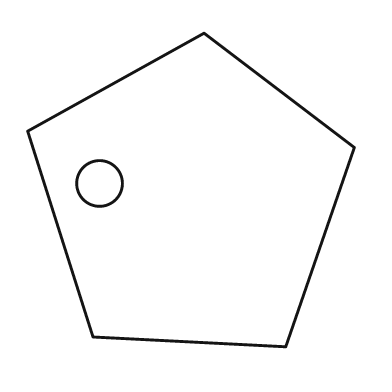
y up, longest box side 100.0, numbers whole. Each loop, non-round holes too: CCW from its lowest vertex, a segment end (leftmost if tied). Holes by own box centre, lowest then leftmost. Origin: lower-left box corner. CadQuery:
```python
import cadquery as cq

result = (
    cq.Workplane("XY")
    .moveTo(79.0, 0.0)
    .lineTo(100.0, 61.0)
    .lineTo(54.0, 96.0)
    .lineTo(0.0, 66.0)
    .lineTo(20.0, 3.0)
    .close()
    .moveTo(22.0, 50.0)
    .circle(7.0)
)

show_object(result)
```